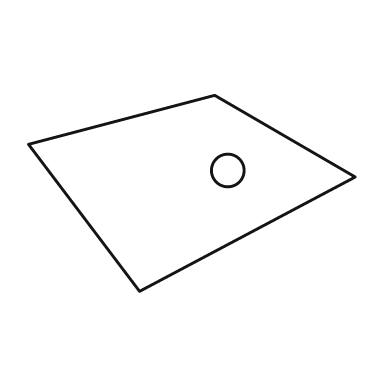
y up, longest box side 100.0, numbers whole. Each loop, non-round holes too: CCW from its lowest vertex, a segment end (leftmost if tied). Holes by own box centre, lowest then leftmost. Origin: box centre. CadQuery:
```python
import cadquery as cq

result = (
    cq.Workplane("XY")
    .moveTo(-16.0, -30.0)
    .lineTo(50.0, 5.0)
    .lineTo(7.0, 30.0)
    .lineTo(-50.0, 15.0)
    .close()
    .moveTo(11.0, 7.0)
    .circle(5.0)
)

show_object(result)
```